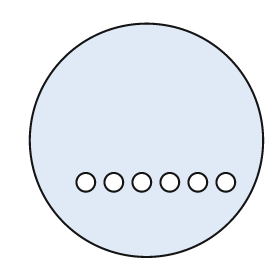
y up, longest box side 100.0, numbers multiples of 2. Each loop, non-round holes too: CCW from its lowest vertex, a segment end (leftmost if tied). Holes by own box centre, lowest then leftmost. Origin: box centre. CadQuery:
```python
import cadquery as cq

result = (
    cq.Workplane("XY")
    .moveTo(0.0, 0.0)
    .circle(50.0)
    .moveTo(-26.0, -18.0)
    .circle(4.0)
    .moveTo(-14.0, -18.0)
    .circle(4.0)
    .moveTo(-2.0, -18.0)
    .circle(4.0)
    .moveTo(10.0, -18.0)
    .circle(4.0)
    .moveTo(22.0, -18.0)
    .circle(4.0)
    .moveTo(34.0, -18.0)
    .circle(4.0)
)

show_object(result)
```